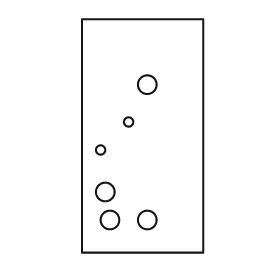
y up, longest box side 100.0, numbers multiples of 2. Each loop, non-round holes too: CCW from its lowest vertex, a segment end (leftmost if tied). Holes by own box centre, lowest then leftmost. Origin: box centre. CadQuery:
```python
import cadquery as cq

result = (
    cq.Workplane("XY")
    .moveTo(-26.0, -50.0)
    .lineTo(26.0, -50.0)
    .lineTo(26.0, 50.0)
    .lineTo(-26.0, 50.0)
    .close()
    .moveTo(-14.0, -36.0)
    .circle(4.0)
    .moveTo(2.0, -36.0)
    .circle(4.0)
    .moveTo(-16.0, -24.0)
    .circle(4.0)
    .moveTo(-18.0, -6.0)
    .circle(2.0)
    .moveTo(-6.0, 6.0)
    .circle(2.0)
    .moveTo(2.0, 22.0)
    .circle(4.0)
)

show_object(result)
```